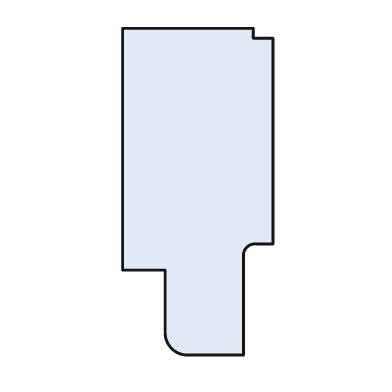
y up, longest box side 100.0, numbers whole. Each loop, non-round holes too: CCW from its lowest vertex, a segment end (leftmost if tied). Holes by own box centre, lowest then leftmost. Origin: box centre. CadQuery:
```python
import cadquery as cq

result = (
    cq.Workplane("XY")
    .moveTo(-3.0, -50.0)
    .lineTo(14.0, -50.0)
    .lineTo(14.0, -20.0)
    .threePointArc((15.0, -17.0), (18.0, -16.0))
    .lineTo(23.0, -16.0)
    .lineTo(23.0, 47.0)
    .lineTo(17.0, 47.0)
    .lineTo(17.0, 50.0)
    .lineTo(-23.0, 50.0)
    .lineTo(-23.0, -24.0)
    .lineTo(-10.0, -24.0)
    .lineTo(-10.0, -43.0)
    .threePointArc((-8.0, -48.0), (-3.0, -50.0))
    .close()
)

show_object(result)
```